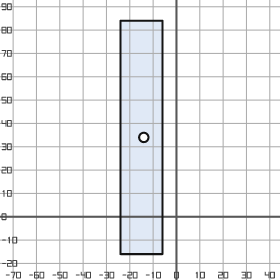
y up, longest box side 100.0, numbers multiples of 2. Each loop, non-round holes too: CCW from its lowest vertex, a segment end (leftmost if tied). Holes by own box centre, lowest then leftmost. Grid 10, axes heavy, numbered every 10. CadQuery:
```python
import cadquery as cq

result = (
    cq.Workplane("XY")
    .moveTo(-24.0, -16.0)
    .lineTo(-6.0, -16.0)
    .lineTo(-6.0, 84.0)
    .lineTo(-24.0, 84.0)
    .close()
    .moveTo(-14.0, 34.0)
    .circle(2.0)
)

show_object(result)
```